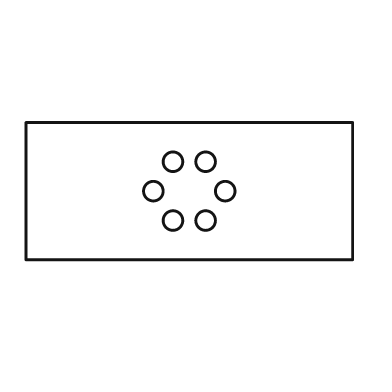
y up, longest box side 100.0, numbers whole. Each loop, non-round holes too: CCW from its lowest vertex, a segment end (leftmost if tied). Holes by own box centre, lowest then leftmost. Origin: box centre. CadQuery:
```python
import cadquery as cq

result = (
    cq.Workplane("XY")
    .moveTo(-50.0, -21.0)
    .lineTo(50.0, -21.0)
    .lineTo(50.0, 21.0)
    .lineTo(-50.0, 21.0)
    .close()
    .moveTo(-5.0, -9.0)
    .circle(3.0)
    .moveTo(5.0, -9.0)
    .circle(3.0)
    .moveTo(-11.0, 0.0)
    .circle(3.0)
    .moveTo(11.0, 0.0)
    .circle(3.0)
    .moveTo(-5.0, 9.0)
    .circle(3.0)
    .moveTo(5.0, 9.0)
    .circle(3.0)
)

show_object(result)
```